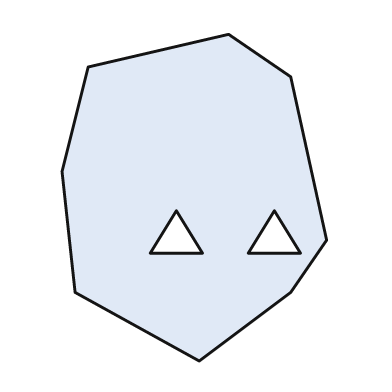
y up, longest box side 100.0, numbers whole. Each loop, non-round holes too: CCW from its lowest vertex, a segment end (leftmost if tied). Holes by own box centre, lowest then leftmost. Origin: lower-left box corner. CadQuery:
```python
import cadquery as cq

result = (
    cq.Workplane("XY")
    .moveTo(42.0, 0.0)
    .lineTo(70.0, 21.0)
    .lineTo(81.0, 37.0)
    .lineTo(70.0, 87.0)
    .lineTo(51.0, 100.0)
    .lineTo(8.0, 90.0)
    .lineTo(0.0, 58.0)
    .lineTo(4.0, 21.0)
    .close()
    .moveTo(27.0, 33.0)
    .lineTo(43.0, 33.0)
    .lineTo(35.0, 46.0)
    .close()
    .moveTo(57.0, 33.0)
    .lineTo(73.0, 33.0)
    .lineTo(65.0, 46.0)
    .close()
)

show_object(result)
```